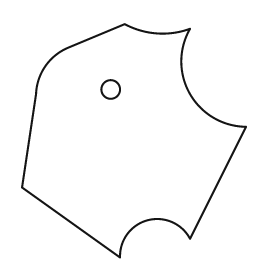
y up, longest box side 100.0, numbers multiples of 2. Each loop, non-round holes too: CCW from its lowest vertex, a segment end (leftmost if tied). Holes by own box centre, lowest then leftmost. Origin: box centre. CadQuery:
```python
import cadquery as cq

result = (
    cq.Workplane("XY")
    .moveTo(-6.0, -50.0)
    .threePointArc((6.0, -34.0), (24.0, -42.0))
    .lineTo(48.0, 6.0)
    .threePointArc((24.0, 20.0), (24.0, 48.0))
    .threePointArc((10.0, 46.0), (-4.0, 50.0))
    .lineTo(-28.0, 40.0)
    .threePointArc((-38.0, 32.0), (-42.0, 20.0))
    .lineTo(-48.0, -20.0)
    .close()
    .moveTo(-10.0, 22.0)
    .circle(4.0)
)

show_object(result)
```